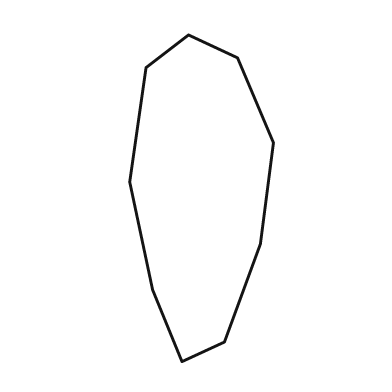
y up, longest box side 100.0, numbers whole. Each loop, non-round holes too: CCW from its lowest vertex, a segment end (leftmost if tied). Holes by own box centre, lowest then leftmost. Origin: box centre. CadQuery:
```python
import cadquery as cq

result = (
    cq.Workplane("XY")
    .moveTo(-6.0, -50.0)
    .lineTo(7.0, -44.0)
    .lineTo(18.0, -14.0)
    .lineTo(22.0, 17.0)
    .lineTo(11.0, 43.0)
    .lineTo(-4.0, 50.0)
    .lineTo(-17.0, 40.0)
    .lineTo(-22.0, 5.0)
    .lineTo(-15.0, -28.0)
    .close()
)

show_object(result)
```